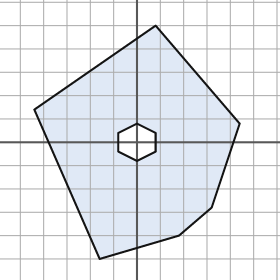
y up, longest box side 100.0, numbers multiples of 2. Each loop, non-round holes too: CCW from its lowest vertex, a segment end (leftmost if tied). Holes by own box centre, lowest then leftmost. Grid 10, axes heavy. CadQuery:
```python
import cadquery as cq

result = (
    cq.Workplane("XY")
    .moveTo(-16.0, -50.0)
    .lineTo(18.0, -40.0)
    .lineTo(32.0, -28.0)
    .lineTo(44.0, 8.0)
    .lineTo(8.0, 50.0)
    .lineTo(-44.0, 14.0)
    .close()
    .moveTo(0.0, -8.0)
    .lineTo(8.0, -4.0)
    .lineTo(8.0, 4.0)
    .lineTo(0.0, 8.0)
    .lineTo(-8.0, 4.0)
    .lineTo(-8.0, -4.0)
    .close()
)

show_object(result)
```